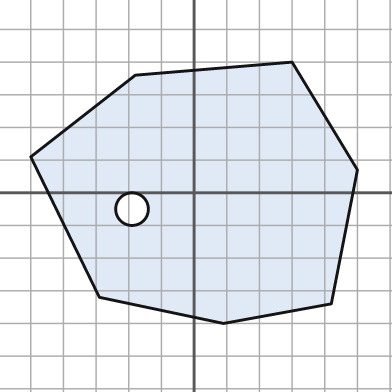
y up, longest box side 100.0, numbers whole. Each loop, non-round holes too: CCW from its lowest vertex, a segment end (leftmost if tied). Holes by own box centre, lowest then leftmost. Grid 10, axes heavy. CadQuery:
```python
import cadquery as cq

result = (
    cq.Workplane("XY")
    .moveTo(9.0, -40.0)
    .lineTo(42.0, -34.0)
    .lineTo(50.0, 7.0)
    .lineTo(30.0, 40.0)
    .lineTo(-18.0, 36.0)
    .lineTo(-50.0, 11.0)
    .lineTo(-29.0, -32.0)
    .close()
    .moveTo(-19.0, -5.0)
    .circle(5.0)
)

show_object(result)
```